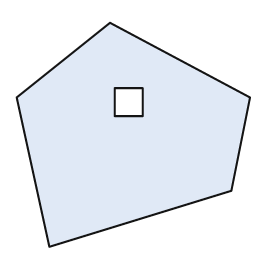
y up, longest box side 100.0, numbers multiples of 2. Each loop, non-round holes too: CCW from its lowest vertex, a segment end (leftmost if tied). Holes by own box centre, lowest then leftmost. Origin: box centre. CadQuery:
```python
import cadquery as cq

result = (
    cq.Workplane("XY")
    .moveTo(-36.0, -48.0)
    .lineTo(42.0, -24.0)
    .lineTo(50.0, 16.0)
    .lineTo(-10.0, 48.0)
    .lineTo(-50.0, 16.0)
    .close()
    .moveTo(-8.0, 8.0)
    .lineTo(4.0, 8.0)
    .lineTo(4.0, 20.0)
    .lineTo(-8.0, 20.0)
    .close()
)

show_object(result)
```